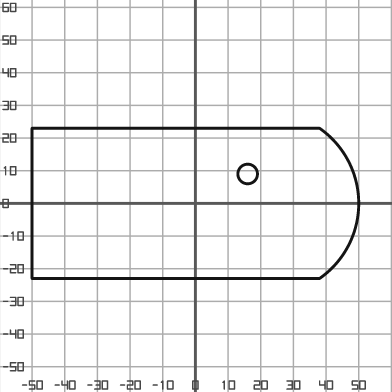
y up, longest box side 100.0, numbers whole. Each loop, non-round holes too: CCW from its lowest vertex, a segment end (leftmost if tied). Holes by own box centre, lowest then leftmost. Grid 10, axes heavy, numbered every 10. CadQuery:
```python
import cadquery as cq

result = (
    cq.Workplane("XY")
    .moveTo(-50.0, -23.0)
    .lineTo(38.0, -23.0)
    .threePointArc((50.0, 0.0), (38.0, 23.0))
    .lineTo(-50.0, 23.0)
    .close()
    .moveTo(16.0, 9.0)
    .circle(3.0)
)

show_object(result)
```